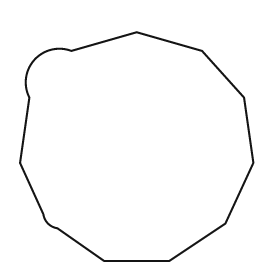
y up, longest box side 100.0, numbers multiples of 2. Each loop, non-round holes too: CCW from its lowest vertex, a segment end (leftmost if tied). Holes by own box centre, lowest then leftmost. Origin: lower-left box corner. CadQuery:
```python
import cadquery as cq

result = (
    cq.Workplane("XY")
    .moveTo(36.0, 0.0)
    .lineTo(64.0, 0.0)
    .lineTo(88.0, 16.0)
    .lineTo(100.0, 42.0)
    .lineTo(96.0, 70.0)
    .lineTo(78.0, 90.0)
    .lineTo(50.0, 98.0)
    .lineTo(22.0, 90.0)
    .threePointArc((6.0, 86.0), (4.0, 70.0))
    .lineTo(0.0, 42.0)
    .lineTo(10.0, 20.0)
    .threePointArc((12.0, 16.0), (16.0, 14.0))
    .close()
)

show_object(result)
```